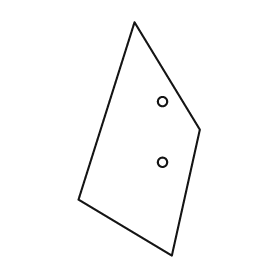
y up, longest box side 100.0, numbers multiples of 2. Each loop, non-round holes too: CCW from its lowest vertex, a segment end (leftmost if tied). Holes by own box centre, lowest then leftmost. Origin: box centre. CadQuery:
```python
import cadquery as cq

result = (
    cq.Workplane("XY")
    .moveTo(14.0, -50.0)
    .lineTo(26.0, 4.0)
    .lineTo(-2.0, 50.0)
    .lineTo(-26.0, -26.0)
    .close()
    .moveTo(10.0, -10.0)
    .circle(2.0)
    .moveTo(10.0, 16.0)
    .circle(2.0)
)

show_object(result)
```